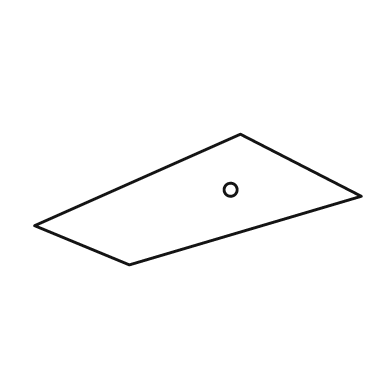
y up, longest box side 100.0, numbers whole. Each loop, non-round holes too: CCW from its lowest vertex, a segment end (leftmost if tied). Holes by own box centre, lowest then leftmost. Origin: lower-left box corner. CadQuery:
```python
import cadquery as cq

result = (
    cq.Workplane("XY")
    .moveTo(29.0, 0.0)
    .lineTo(100.0, 21.0)
    .lineTo(63.0, 40.0)
    .lineTo(0.0, 12.0)
    .close()
    .moveTo(60.0, 23.0)
    .circle(2.0)
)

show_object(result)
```